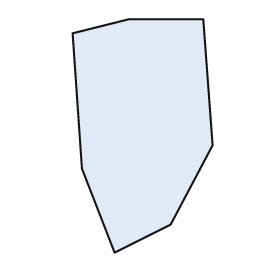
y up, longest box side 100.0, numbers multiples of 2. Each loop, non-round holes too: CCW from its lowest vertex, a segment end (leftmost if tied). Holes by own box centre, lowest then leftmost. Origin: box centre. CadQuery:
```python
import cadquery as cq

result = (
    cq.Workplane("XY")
    .moveTo(-12.0, -50.0)
    .lineTo(12.0, -38.0)
    .lineTo(30.0, -4.0)
    .lineTo(26.0, 50.0)
    .lineTo(-6.0, 50.0)
    .lineTo(-30.0, 44.0)
    .lineTo(-26.0, -14.0)
    .close()
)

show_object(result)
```